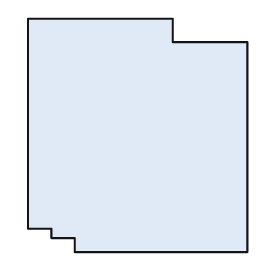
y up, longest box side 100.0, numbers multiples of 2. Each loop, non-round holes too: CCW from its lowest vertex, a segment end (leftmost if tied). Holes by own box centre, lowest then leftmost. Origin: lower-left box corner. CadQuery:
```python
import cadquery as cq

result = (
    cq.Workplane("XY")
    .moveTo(20.0, 0.0)
    .lineTo(94.0, 0.0)
    .lineTo(94.0, 90.0)
    .lineTo(62.0, 90.0)
    .lineTo(62.0, 100.0)
    .lineTo(0.0, 100.0)
    .lineTo(0.0, 10.0)
    .lineTo(10.0, 10.0)
    .lineTo(10.0, 6.0)
    .lineTo(20.0, 6.0)
    .close()
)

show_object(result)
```